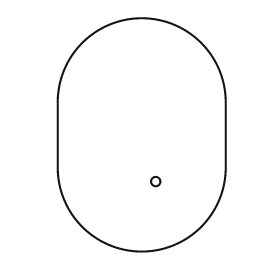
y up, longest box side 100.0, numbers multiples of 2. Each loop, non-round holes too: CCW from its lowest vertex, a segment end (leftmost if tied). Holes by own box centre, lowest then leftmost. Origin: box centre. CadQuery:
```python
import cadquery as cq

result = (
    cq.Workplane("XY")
    .moveTo(-36.0, -14.0)
    .threePointArc((0.0, -50.0), (36.0, -14.0))
    .lineTo(36.0, 14.0)
    .threePointArc((0.0, 50.0), (-36.0, 14.0))
    .close()
    .moveTo(6.0, -20.0)
    .circle(2.0)
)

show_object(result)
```